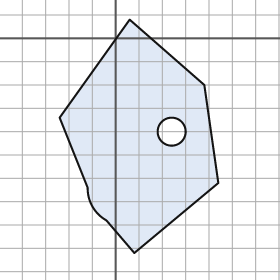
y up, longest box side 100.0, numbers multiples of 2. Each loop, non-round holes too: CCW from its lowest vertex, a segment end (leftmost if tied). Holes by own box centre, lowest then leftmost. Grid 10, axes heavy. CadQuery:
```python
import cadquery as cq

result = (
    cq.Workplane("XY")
    .moveTo(8.0, -92.0)
    .lineTo(44.0, -62.0)
    .lineTo(38.0, -20.0)
    .lineTo(6.0, 8.0)
    .lineTo(-24.0, -34.0)
    .lineTo(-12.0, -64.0)
    .threePointArc((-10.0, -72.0), (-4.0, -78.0))
    .close()
    .moveTo(24.0, -40.0)
    .circle(6.0)
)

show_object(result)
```